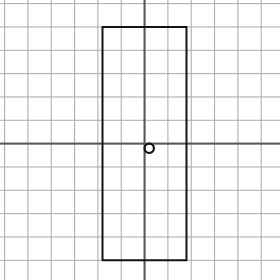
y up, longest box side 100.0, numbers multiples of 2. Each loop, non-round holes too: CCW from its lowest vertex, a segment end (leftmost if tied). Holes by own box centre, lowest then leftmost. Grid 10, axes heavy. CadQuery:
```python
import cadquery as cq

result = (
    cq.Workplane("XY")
    .moveTo(-18.0, -50.0)
    .lineTo(18.0, -50.0)
    .lineTo(18.0, 50.0)
    .lineTo(-18.0, 50.0)
    .close()
    .moveTo(2.0, -2.0)
    .circle(2.0)
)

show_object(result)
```